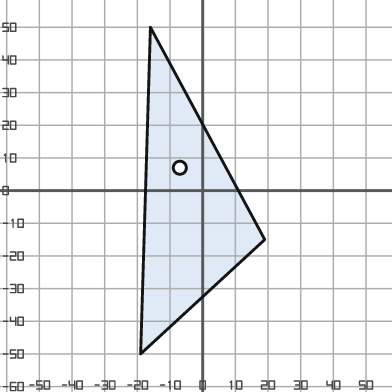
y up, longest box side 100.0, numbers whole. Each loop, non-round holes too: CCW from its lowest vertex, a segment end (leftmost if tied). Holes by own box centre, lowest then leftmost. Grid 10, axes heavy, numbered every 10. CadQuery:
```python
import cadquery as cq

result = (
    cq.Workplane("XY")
    .moveTo(-19.0, -50.0)
    .lineTo(19.0, -15.0)
    .lineTo(-16.0, 50.0)
    .close()
    .moveTo(-7.0, 7.0)
    .circle(2.0)
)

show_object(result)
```